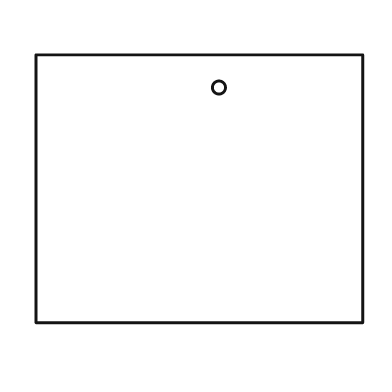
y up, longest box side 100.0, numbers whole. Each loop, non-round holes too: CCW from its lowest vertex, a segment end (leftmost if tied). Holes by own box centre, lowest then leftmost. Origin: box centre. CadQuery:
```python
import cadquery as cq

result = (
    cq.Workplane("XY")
    .moveTo(-50.0, -41.0)
    .lineTo(50.0, -41.0)
    .lineTo(50.0, 41.0)
    .lineTo(-50.0, 41.0)
    .close()
    .moveTo(6.0, 31.0)
    .circle(2.0)
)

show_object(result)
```